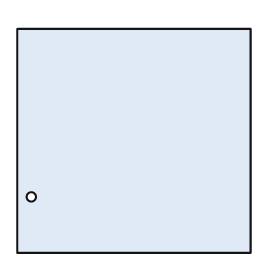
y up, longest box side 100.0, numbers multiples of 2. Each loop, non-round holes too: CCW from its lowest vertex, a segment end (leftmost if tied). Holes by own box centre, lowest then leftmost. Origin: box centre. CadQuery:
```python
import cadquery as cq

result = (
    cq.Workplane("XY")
    .moveTo(-50.0, -48.0)
    .lineTo(50.0, -48.0)
    .lineTo(50.0, 48.0)
    .lineTo(-50.0, 48.0)
    .close()
    .moveTo(-44.0, -24.0)
    .circle(2.0)
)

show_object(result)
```